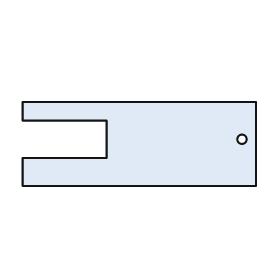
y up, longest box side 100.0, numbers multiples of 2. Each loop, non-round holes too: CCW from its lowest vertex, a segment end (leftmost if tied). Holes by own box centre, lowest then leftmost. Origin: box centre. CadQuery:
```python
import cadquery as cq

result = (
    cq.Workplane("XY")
    .moveTo(-50.0, -18.0)
    .lineTo(50.0, -18.0)
    .lineTo(50.0, 18.0)
    .lineTo(-50.0, 18.0)
    .lineTo(-50.0, 10.0)
    .lineTo(-14.0, 10.0)
    .lineTo(-14.0, -6.0)
    .lineTo(-50.0, -6.0)
    .close()
    .moveTo(44.0, 2.0)
    .circle(2.0)
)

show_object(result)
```